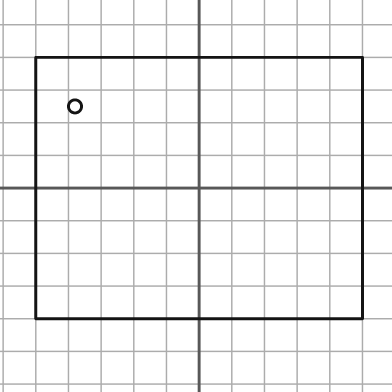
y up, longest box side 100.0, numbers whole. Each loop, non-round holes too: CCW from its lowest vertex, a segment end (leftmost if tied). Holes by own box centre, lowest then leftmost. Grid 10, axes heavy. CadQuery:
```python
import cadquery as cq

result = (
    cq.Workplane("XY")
    .moveTo(-50.0, -40.0)
    .lineTo(50.0, -40.0)
    .lineTo(50.0, 40.0)
    .lineTo(-50.0, 40.0)
    .close()
    .moveTo(-38.0, 25.0)
    .circle(2.0)
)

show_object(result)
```